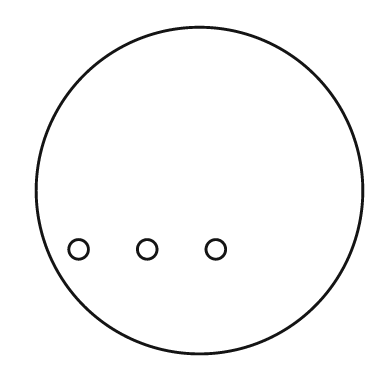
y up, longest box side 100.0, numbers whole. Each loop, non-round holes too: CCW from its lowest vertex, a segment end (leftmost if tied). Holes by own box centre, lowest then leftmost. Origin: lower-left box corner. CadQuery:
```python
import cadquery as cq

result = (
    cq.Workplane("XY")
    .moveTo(50.0, 50.0)
    .circle(50.0)
    .moveTo(13.0, 32.0)
    .circle(3.0)
    .moveTo(34.0, 32.0)
    .circle(3.0)
    .moveTo(55.0, 32.0)
    .circle(3.0)
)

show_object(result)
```